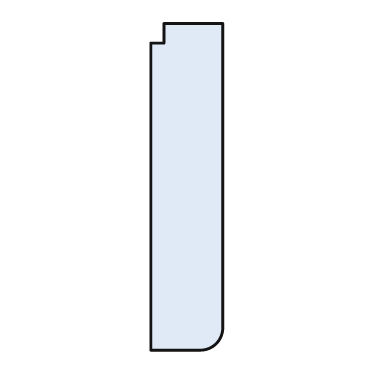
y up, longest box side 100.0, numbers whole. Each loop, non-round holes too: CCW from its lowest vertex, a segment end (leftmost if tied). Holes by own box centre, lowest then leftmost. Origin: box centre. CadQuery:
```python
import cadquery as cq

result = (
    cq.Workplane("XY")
    .moveTo(-11.0, -50.0)
    .lineTo(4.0, -50.0)
    .threePointArc((9.0, -48.0), (11.0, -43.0))
    .lineTo(11.0, 50.0)
    .lineTo(-7.0, 50.0)
    .lineTo(-7.0, 44.0)
    .lineTo(-11.0, 44.0)
    .close()
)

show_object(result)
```